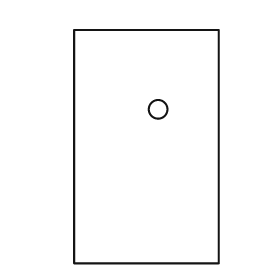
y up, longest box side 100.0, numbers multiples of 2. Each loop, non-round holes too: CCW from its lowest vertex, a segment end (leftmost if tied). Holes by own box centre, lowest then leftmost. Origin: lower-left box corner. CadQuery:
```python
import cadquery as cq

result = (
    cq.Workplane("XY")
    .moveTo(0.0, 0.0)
    .lineTo(62.0, 0.0)
    .lineTo(62.0, 100.0)
    .lineTo(0.0, 100.0)
    .close()
    .moveTo(36.0, 66.0)
    .circle(4.0)
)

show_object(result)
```